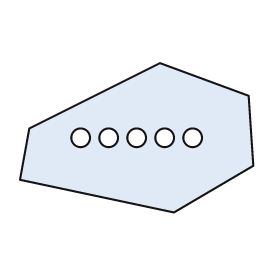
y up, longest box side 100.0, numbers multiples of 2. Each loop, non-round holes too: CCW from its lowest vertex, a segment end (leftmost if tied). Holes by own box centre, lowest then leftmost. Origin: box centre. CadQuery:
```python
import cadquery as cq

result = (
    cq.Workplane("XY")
    .moveTo(16.0, -32.0)
    .lineTo(50.0, -12.0)
    .lineTo(48.0, 18.0)
    .lineTo(10.0, 32.0)
    .lineTo(-46.0, 4.0)
    .lineTo(-50.0, -18.0)
    .close()
    .moveTo(-24.0, 0.0)
    .circle(4.0)
    .moveTo(-12.0, 0.0)
    .circle(4.0)
    .moveTo(0.0, 0.0)
    .circle(4.0)
    .moveTo(12.0, 0.0)
    .circle(4.0)
    .moveTo(24.0, 0.0)
    .circle(4.0)
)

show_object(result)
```